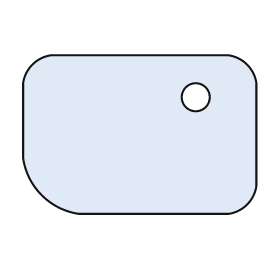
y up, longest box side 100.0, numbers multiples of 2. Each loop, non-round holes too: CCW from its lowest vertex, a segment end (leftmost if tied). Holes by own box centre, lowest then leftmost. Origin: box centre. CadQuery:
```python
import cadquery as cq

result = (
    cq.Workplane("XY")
    .moveTo(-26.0, -34.0)
    .lineTo(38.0, -34.0)
    .threePointArc((46.0, -30.0), (50.0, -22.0))
    .lineTo(50.0, 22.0)
    .threePointArc((46.0, 30.0), (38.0, 34.0))
    .lineTo(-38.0, 34.0)
    .threePointArc((-46.0, 30.0), (-50.0, 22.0))
    .lineTo(-50.0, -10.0)
    .threePointArc((-42.0, -26.0), (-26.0, -34.0))
    .close()
    .moveTo(24.0, 16.0)
    .circle(6.0)
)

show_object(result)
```